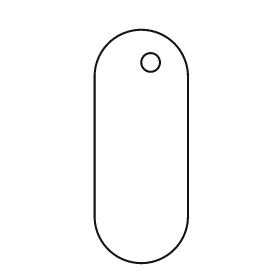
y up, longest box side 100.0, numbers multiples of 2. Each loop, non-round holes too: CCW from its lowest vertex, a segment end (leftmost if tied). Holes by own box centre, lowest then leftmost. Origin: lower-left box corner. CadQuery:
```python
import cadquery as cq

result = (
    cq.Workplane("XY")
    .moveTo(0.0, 20.0)
    .threePointArc((20.0, 0.0), (40.0, 20.0))
    .lineTo(40.0, 80.0)
    .threePointArc((20.0, 100.0), (0.0, 80.0))
    .close()
    .moveTo(24.0, 86.0)
    .circle(4.0)
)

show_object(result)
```